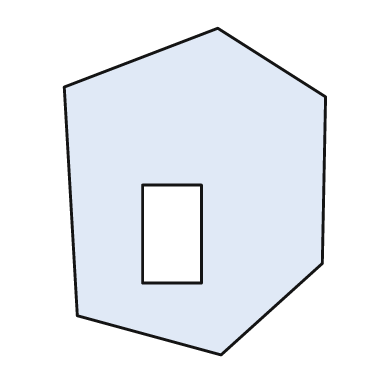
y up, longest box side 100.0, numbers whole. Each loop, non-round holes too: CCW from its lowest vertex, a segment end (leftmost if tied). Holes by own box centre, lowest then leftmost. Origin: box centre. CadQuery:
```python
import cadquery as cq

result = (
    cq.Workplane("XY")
    .moveTo(8.0, -50.0)
    .lineTo(39.0, -22.0)
    .lineTo(40.0, 29.0)
    .lineTo(7.0, 50.0)
    .lineTo(-40.0, 32.0)
    .lineTo(-36.0, -38.0)
    .close()
    .moveTo(-16.0, -28.0)
    .lineTo(2.0, -28.0)
    .lineTo(2.0, 2.0)
    .lineTo(-16.0, 2.0)
    .close()
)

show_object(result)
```